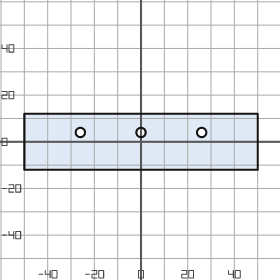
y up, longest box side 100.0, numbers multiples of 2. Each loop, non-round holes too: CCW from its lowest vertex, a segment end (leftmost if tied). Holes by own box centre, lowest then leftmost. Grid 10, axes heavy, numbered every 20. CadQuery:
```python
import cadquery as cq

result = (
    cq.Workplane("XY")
    .moveTo(-50.0, -12.0)
    .lineTo(50.0, -12.0)
    .lineTo(50.0, 12.0)
    .lineTo(-50.0, 12.0)
    .close()
    .moveTo(-26.0, 4.0)
    .circle(2.0)
    .moveTo(0.0, 4.0)
    .circle(2.0)
    .moveTo(26.0, 4.0)
    .circle(2.0)
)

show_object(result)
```